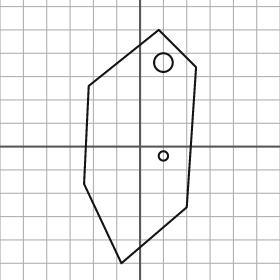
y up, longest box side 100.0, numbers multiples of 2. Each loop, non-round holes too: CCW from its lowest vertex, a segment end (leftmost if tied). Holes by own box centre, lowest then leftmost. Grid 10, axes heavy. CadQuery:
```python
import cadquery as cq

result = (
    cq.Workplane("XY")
    .moveTo(-8.0, -50.0)
    .lineTo(20.0, -26.0)
    .lineTo(24.0, 34.0)
    .lineTo(8.0, 50.0)
    .lineTo(-22.0, 26.0)
    .lineTo(-24.0, -16.0)
    .close()
    .moveTo(10.0, -4.0)
    .circle(2.0)
    .moveTo(10.0, 36.0)
    .circle(4.0)
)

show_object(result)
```